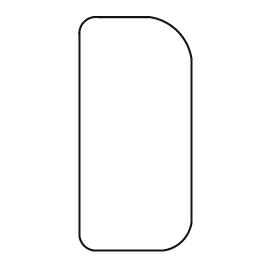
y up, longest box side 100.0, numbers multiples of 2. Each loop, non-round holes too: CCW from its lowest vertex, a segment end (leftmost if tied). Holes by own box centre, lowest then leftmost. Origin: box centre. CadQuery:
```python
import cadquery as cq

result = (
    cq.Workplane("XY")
    .moveTo(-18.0, -50.0)
    .lineTo(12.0, -50.0)
    .threePointArc((20.0, -46.0), (24.0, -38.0))
    .lineTo(24.0, 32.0)
    .threePointArc((18.0, 44.0), (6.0, 50.0))
    .lineTo(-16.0, 50.0)
    .threePointArc((-22.0, 48.0), (-24.0, 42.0))
    .lineTo(-24.0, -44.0)
    .threePointArc((-22.0, -48.0), (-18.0, -50.0))
    .close()
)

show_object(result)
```